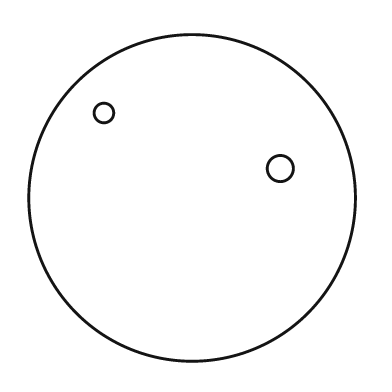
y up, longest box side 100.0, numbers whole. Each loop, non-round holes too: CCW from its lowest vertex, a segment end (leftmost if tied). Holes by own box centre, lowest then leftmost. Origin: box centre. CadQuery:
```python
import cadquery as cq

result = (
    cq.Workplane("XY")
    .moveTo(0.0, 0.0)
    .circle(50.0)
    .moveTo(27.0, 9.0)
    .circle(4.0)
    .moveTo(-27.0, 26.0)
    .circle(3.0)
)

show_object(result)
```